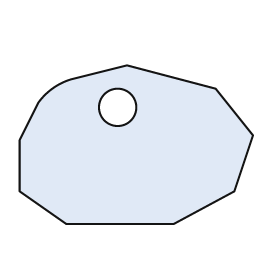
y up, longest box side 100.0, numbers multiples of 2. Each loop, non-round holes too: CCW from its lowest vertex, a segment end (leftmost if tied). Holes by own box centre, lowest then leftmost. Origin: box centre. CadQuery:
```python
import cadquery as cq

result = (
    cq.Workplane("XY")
    .moveTo(-30.0, -34.0)
    .lineTo(16.0, -34.0)
    .lineTo(42.0, -20.0)
    .lineTo(50.0, 4.0)
    .lineTo(34.0, 24.0)
    .lineTo(-4.0, 34.0)
    .lineTo(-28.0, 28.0)
    .threePointArc((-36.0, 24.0), (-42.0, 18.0))
    .lineTo(-50.0, 2.0)
    .lineTo(-50.0, -20.0)
    .close()
    .moveTo(-8.0, 16.0)
    .circle(8.0)
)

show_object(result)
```